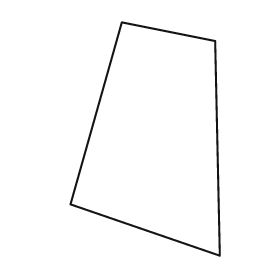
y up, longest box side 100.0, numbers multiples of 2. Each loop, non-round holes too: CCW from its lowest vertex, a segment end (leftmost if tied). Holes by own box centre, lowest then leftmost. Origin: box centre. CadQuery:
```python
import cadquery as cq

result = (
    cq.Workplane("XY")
    .moveTo(32.0, -50.0)
    .lineTo(30.0, 42.0)
    .lineTo(-10.0, 50.0)
    .lineTo(-32.0, -28.0)
    .close()
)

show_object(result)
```